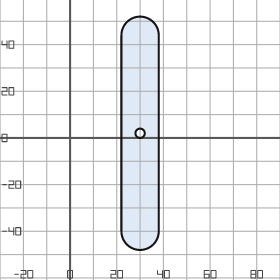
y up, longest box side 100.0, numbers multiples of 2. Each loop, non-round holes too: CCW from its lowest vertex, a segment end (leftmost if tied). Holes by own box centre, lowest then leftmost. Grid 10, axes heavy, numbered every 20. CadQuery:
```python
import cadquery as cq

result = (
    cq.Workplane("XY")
    .moveTo(22.0, -40.0)
    .threePointArc((30.0, -48.0), (38.0, -40.0))
    .lineTo(38.0, 44.0)
    .threePointArc((30.0, 52.0), (22.0, 44.0))
    .close()
    .moveTo(30.0, 2.0)
    .circle(2.0)
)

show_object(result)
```